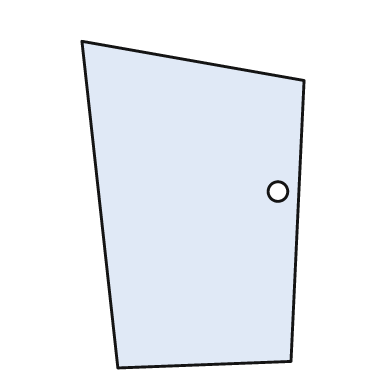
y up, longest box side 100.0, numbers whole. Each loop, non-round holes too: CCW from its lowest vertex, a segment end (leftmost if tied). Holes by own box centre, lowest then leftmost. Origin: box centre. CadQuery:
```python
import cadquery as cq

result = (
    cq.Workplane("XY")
    .moveTo(-23.0, -50.0)
    .lineTo(30.0, -48.0)
    .lineTo(34.0, 38.0)
    .lineTo(-34.0, 50.0)
    .close()
    .moveTo(26.0, 4.0)
    .circle(3.0)
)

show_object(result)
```